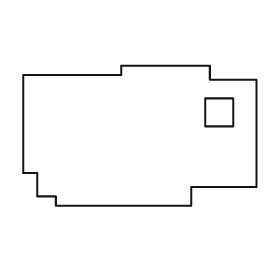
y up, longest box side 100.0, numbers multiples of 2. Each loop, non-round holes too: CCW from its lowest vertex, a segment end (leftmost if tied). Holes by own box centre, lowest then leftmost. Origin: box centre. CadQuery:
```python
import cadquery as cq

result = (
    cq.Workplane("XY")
    .moveTo(-36.0, -30.0)
    .lineTo(22.0, -30.0)
    .lineTo(22.0, -22.0)
    .lineTo(50.0, -22.0)
    .lineTo(50.0, 24.0)
    .lineTo(30.0, 24.0)
    .lineTo(30.0, 30.0)
    .lineTo(-8.0, 30.0)
    .lineTo(-8.0, 26.0)
    .lineTo(-50.0, 26.0)
    .lineTo(-50.0, -16.0)
    .lineTo(-44.0, -16.0)
    .lineTo(-44.0, -26.0)
    .lineTo(-36.0, -26.0)
    .close()
    .moveTo(28.0, 4.0)
    .lineTo(40.0, 4.0)
    .lineTo(40.0, 16.0)
    .lineTo(28.0, 16.0)
    .close()
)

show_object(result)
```